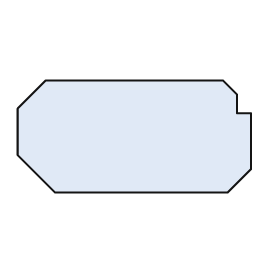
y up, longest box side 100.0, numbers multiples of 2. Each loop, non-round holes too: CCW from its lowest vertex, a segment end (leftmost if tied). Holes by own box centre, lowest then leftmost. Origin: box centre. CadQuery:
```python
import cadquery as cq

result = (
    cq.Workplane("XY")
    .moveTo(-34.0, -24.0)
    .lineTo(40.0, -24.0)
    .lineTo(50.0, -14.0)
    .lineTo(50.0, 10.0)
    .lineTo(44.0, 10.0)
    .lineTo(44.0, 18.0)
    .lineTo(38.0, 24.0)
    .lineTo(-38.0, 24.0)
    .lineTo(-50.0, 12.0)
    .lineTo(-50.0, -8.0)
    .close()
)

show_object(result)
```